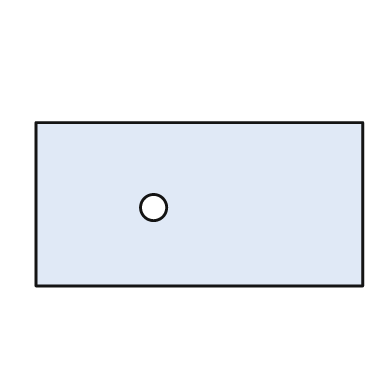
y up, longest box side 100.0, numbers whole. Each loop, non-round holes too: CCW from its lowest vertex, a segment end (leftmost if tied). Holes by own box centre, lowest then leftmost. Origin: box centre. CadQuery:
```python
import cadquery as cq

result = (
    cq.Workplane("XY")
    .moveTo(-50.0, -25.0)
    .lineTo(50.0, -25.0)
    .lineTo(50.0, 25.0)
    .lineTo(-50.0, 25.0)
    .close()
    .moveTo(-14.0, -1.0)
    .circle(4.0)
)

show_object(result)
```